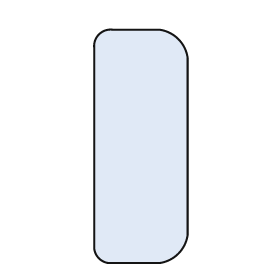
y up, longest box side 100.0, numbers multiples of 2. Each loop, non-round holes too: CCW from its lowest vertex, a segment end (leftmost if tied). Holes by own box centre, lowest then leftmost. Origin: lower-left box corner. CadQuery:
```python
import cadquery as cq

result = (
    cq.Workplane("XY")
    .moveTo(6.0, 0.0)
    .lineTo(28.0, 0.0)
    .threePointArc((36.0, 4.0), (40.0, 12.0))
    .lineTo(40.0, 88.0)
    .threePointArc((36.0, 96.0), (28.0, 100.0))
    .lineTo(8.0, 100.0)
    .threePointArc((2.0, 98.0), (0.0, 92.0))
    .lineTo(0.0, 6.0)
    .threePointArc((2.0, 2.0), (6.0, 0.0))
    .close()
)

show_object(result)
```